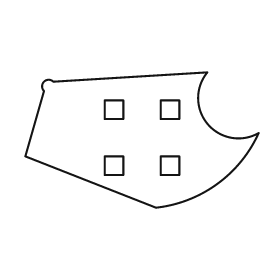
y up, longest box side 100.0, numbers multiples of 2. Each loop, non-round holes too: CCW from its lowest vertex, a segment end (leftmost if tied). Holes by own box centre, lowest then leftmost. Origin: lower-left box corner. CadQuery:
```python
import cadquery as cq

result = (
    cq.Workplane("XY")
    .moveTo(56.0, 0.0)
    .threePointArc((82.0, 10.0), (100.0, 32.0))
    .threePointArc((78.0, 36.0), (78.0, 58.0))
    .lineTo(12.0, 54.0)
    .threePointArc((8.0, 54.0), (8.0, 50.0))
    .lineTo(0.0, 22.0)
    .close()
    .moveTo(34.0, 14.0)
    .lineTo(42.0, 14.0)
    .lineTo(42.0, 22.0)
    .lineTo(34.0, 22.0)
    .close()
    .moveTo(58.0, 14.0)
    .lineTo(66.0, 14.0)
    .lineTo(66.0, 22.0)
    .lineTo(58.0, 22.0)
    .close()
    .moveTo(34.0, 38.0)
    .lineTo(42.0, 38.0)
    .lineTo(42.0, 46.0)
    .lineTo(34.0, 46.0)
    .close()
    .moveTo(58.0, 38.0)
    .lineTo(66.0, 38.0)
    .lineTo(66.0, 46.0)
    .lineTo(58.0, 46.0)
    .close()
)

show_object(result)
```